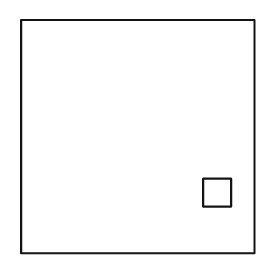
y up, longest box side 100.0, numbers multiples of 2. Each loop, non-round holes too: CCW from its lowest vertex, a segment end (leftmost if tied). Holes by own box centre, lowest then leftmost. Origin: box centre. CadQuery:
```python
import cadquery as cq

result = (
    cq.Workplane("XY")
    .moveTo(-50.0, -50.0)
    .lineTo(50.0, -50.0)
    .lineTo(50.0, 50.0)
    .lineTo(-50.0, 50.0)
    .close()
    .moveTo(28.0, -30.0)
    .lineTo(40.0, -30.0)
    .lineTo(40.0, -18.0)
    .lineTo(28.0, -18.0)
    .close()
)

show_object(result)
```